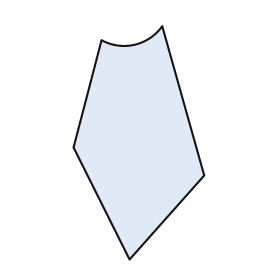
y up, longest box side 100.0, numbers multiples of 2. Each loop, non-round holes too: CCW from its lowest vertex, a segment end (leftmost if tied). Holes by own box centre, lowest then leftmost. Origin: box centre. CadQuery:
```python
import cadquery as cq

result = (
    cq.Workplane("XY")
    .moveTo(-4.0, -50.0)
    .lineTo(28.0, -14.0)
    .lineTo(10.0, 50.0)
    .threePointArc((-2.0, 42.0), (-16.0, 44.0))
    .lineTo(-28.0, -2.0)
    .close()
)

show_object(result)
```